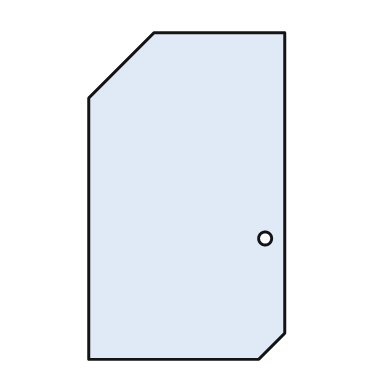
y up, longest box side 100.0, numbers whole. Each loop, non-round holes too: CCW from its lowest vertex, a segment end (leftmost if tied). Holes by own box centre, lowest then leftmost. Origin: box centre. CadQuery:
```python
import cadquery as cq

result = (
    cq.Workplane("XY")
    .moveTo(-30.0, -50.0)
    .lineTo(22.0, -50.0)
    .lineTo(30.0, -42.0)
    .lineTo(30.0, 50.0)
    .lineTo(-10.0, 50.0)
    .lineTo(-30.0, 30.0)
    .close()
    .moveTo(24.0, -13.0)
    .circle(2.0)
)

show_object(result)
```